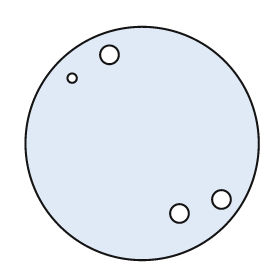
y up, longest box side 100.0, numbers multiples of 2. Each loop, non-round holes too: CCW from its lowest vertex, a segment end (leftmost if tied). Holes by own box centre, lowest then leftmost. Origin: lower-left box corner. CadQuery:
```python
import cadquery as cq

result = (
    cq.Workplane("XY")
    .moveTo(50.0, 50.0)
    .circle(50.0)
    .moveTo(66.0, 20.0)
    .circle(4.0)
    .moveTo(84.0, 26.0)
    .circle(4.0)
    .moveTo(20.0, 78.0)
    .circle(2.0)
    .moveTo(36.0, 88.0)
    .circle(4.0)
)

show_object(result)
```